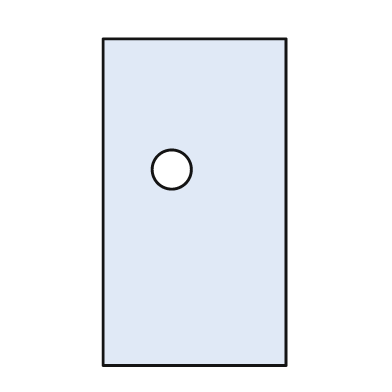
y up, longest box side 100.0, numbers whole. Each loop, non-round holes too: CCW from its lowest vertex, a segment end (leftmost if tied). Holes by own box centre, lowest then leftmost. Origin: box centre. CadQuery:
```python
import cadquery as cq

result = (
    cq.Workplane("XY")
    .moveTo(-28.0, -50.0)
    .lineTo(28.0, -50.0)
    .lineTo(28.0, 50.0)
    .lineTo(-28.0, 50.0)
    .close()
    .moveTo(-7.0, 10.0)
    .circle(6.0)
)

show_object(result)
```